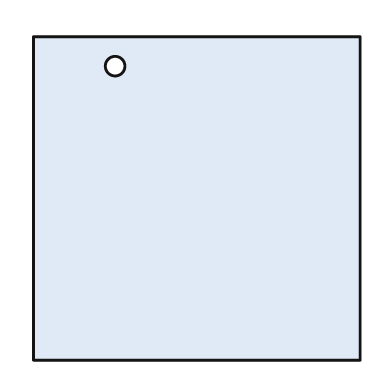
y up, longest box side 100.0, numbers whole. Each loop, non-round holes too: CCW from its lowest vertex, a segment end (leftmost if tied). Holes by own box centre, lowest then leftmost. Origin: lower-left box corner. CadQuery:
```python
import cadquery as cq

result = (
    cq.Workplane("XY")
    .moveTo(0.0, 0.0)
    .lineTo(100.0, 0.0)
    .lineTo(100.0, 99.0)
    .lineTo(0.0, 99.0)
    .close()
    .moveTo(25.0, 90.0)
    .circle(3.0)
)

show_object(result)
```